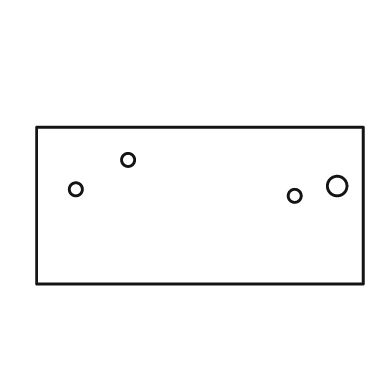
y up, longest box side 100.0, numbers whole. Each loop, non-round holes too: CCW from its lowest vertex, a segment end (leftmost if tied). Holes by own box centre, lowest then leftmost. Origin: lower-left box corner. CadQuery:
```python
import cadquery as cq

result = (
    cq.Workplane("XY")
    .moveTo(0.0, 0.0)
    .lineTo(100.0, 0.0)
    .lineTo(100.0, 48.0)
    .lineTo(0.0, 48.0)
    .close()
    .moveTo(79.0, 27.0)
    .circle(2.0)
    .moveTo(12.0, 29.0)
    .circle(2.0)
    .moveTo(92.0, 30.0)
    .circle(3.0)
    .moveTo(28.0, 38.0)
    .circle(2.0)
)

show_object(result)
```